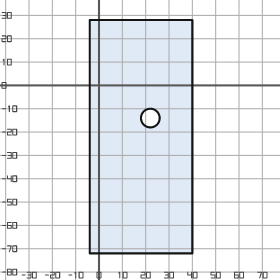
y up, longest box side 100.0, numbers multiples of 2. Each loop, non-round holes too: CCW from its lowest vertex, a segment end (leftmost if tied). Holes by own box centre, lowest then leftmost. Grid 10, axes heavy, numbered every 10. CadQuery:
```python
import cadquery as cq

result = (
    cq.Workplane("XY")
    .moveTo(-4.0, -72.0)
    .lineTo(40.0, -72.0)
    .lineTo(40.0, 28.0)
    .lineTo(-4.0, 28.0)
    .close()
    .moveTo(22.0, -14.0)
    .circle(4.0)
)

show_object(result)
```